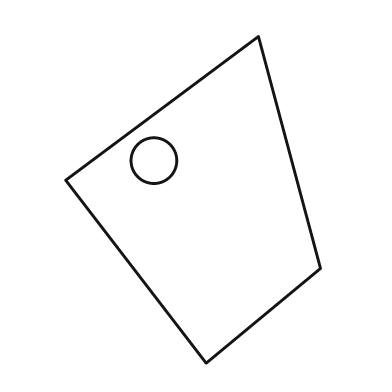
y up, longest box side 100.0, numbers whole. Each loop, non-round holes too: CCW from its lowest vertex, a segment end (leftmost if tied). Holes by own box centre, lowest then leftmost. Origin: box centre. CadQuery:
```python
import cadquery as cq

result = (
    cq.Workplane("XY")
    .moveTo(4.0, -50.0)
    .lineTo(39.0, -21.0)
    .lineTo(20.0, 50.0)
    .lineTo(-39.0, 6.0)
    .close()
    .moveTo(-12.0, 12.0)
    .circle(7.0)
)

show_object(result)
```